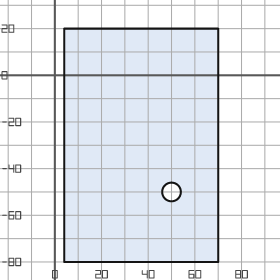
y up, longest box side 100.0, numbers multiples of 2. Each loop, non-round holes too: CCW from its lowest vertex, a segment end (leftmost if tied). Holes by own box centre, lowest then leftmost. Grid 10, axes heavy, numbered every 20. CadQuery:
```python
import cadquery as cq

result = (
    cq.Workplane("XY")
    .moveTo(4.0, -80.0)
    .lineTo(70.0, -80.0)
    .lineTo(70.0, 20.0)
    .lineTo(4.0, 20.0)
    .close()
    .moveTo(50.0, -50.0)
    .circle(4.0)
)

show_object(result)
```